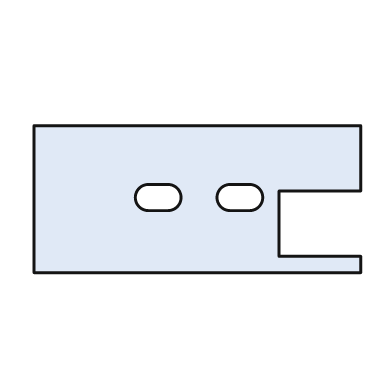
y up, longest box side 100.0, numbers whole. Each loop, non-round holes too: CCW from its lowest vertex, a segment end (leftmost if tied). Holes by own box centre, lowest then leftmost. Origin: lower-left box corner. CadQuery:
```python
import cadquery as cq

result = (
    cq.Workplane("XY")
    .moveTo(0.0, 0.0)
    .lineTo(100.0, 0.0)
    .lineTo(100.0, 5.0)
    .lineTo(75.0, 5.0)
    .lineTo(75.0, 25.0)
    .lineTo(100.0, 25.0)
    .lineTo(100.0, 45.0)
    .lineTo(0.0, 45.0)
    .close()
    .moveTo(35.0, 19.0)
    .lineTo(41.0, 19.0)
    .threePointArc((45.0, 23.0), (41.0, 27.0))
    .lineTo(35.0, 27.0)
    .threePointArc((31.0, 23.0), (35.0, 19.0))
    .close()
    .moveTo(60.0, 19.0)
    .lineTo(66.0, 19.0)
    .threePointArc((70.0, 23.0), (66.0, 27.0))
    .lineTo(60.0, 27.0)
    .threePointArc((56.0, 23.0), (60.0, 19.0))
    .close()
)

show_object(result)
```